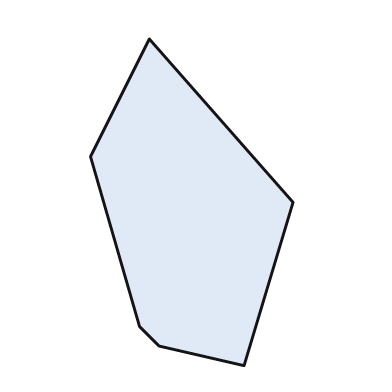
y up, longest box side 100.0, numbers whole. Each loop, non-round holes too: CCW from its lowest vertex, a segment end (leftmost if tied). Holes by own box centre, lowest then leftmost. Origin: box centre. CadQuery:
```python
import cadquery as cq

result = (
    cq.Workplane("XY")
    .moveTo(16.0, -50.0)
    .lineTo(31.0, 0.0)
    .lineTo(-13.0, 50.0)
    .lineTo(-31.0, 14.0)
    .lineTo(-16.0, -38.0)
    .lineTo(-10.0, -44.0)
    .close()
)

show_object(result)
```